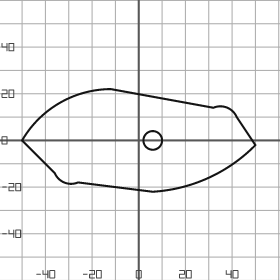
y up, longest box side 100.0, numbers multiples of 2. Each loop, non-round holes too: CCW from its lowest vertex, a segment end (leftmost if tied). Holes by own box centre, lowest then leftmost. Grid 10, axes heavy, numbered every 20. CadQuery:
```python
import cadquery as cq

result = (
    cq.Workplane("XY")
    .moveTo(6.0, -22.0)
    .threePointArc((30.0, -16.0), (50.0, -2.0))
    .lineTo(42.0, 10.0)
    .threePointArc((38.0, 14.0), (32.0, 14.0))
    .lineTo(-12.0, 22.0)
    .threePointArc((-34.0, 16.0), (-50.0, 0.0))
    .lineTo(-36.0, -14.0)
    .threePointArc((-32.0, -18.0), (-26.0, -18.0))
    .close()
    .moveTo(6.0, 0.0)
    .circle(4.0)
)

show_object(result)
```